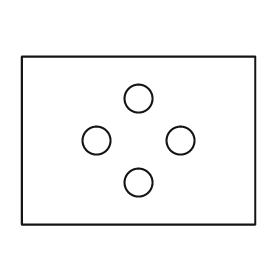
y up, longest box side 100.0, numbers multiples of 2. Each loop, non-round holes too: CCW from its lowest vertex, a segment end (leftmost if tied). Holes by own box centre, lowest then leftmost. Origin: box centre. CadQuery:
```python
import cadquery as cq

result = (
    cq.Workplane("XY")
    .moveTo(-50.0, -36.0)
    .lineTo(50.0, -36.0)
    .lineTo(50.0, 36.0)
    .lineTo(-50.0, 36.0)
    .close()
    .moveTo(0.0, -18.0)
    .circle(6.0)
    .moveTo(-18.0, 0.0)
    .circle(6.0)
    .moveTo(18.0, 0.0)
    .circle(6.0)
    .moveTo(0.0, 18.0)
    .circle(6.0)
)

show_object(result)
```